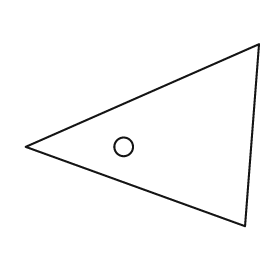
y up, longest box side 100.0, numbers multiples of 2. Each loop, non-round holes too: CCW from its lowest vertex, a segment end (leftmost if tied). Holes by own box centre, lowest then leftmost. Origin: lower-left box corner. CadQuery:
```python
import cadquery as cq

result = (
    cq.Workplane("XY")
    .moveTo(94.0, 0.0)
    .lineTo(100.0, 78.0)
    .lineTo(0.0, 34.0)
    .close()
    .moveTo(42.0, 34.0)
    .circle(4.0)
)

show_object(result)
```